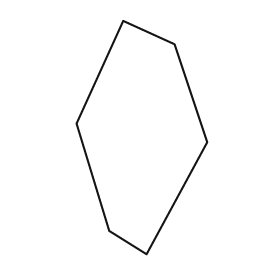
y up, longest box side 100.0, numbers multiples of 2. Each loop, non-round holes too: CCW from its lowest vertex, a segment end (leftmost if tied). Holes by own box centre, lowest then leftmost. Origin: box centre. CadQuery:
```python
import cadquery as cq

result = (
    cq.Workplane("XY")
    .moveTo(2.0, -50.0)
    .lineTo(28.0, -2.0)
    .lineTo(14.0, 40.0)
    .lineTo(-8.0, 50.0)
    .lineTo(-28.0, 6.0)
    .lineTo(-14.0, -40.0)
    .close()
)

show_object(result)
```